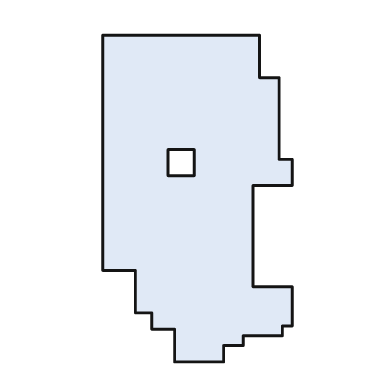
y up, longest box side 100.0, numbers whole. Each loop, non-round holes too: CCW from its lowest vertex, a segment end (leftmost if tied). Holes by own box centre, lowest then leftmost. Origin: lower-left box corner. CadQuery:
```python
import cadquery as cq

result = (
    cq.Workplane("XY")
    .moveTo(22.0, 0.0)
    .lineTo(37.0, 0.0)
    .lineTo(37.0, 5.0)
    .lineTo(43.0, 5.0)
    .lineTo(43.0, 8.0)
    .lineTo(55.0, 8.0)
    .lineTo(55.0, 11.0)
    .lineTo(58.0, 11.0)
    .lineTo(58.0, 23.0)
    .lineTo(46.0, 23.0)
    .lineTo(46.0, 54.0)
    .lineTo(58.0, 54.0)
    .lineTo(58.0, 62.0)
    .lineTo(54.0, 62.0)
    .lineTo(54.0, 87.0)
    .lineTo(48.0, 87.0)
    .lineTo(48.0, 100.0)
    .lineTo(0.0, 100.0)
    .lineTo(0.0, 28.0)
    .lineTo(10.0, 28.0)
    .lineTo(10.0, 15.0)
    .lineTo(15.0, 15.0)
    .lineTo(15.0, 10.0)
    .lineTo(22.0, 10.0)
    .close()
    .moveTo(20.0, 57.0)
    .lineTo(28.0, 57.0)
    .lineTo(28.0, 65.0)
    .lineTo(20.0, 65.0)
    .close()
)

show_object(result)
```